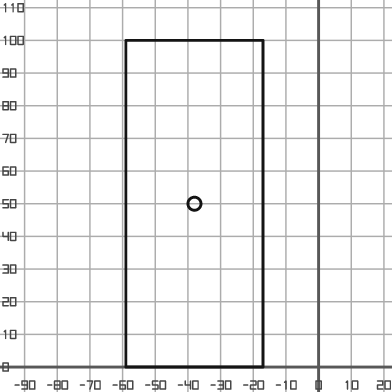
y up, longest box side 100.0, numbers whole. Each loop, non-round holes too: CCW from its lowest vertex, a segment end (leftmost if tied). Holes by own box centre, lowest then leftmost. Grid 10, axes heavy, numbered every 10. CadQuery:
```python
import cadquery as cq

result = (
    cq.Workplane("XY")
    .moveTo(-59.0, 0.0)
    .lineTo(-17.0, 0.0)
    .lineTo(-17.0, 100.0)
    .lineTo(-59.0, 100.0)
    .close()
    .moveTo(-38.0, 50.0)
    .circle(2.0)
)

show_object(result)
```